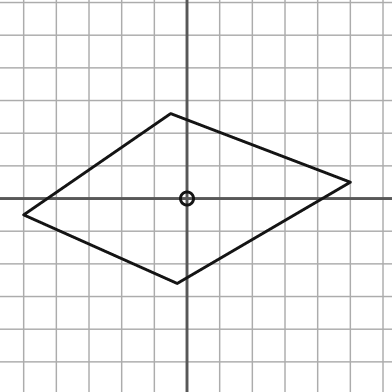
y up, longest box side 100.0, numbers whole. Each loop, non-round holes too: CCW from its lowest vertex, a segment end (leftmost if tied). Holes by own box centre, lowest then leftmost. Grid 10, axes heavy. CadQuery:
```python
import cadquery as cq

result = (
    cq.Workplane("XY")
    .moveTo(-3.0, -26.0)
    .lineTo(50.0, 5.0)
    .lineTo(-5.0, 26.0)
    .lineTo(-50.0, -5.0)
    .close()
    .moveTo(0.0, 0.0)
    .circle(2.0)
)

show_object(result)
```